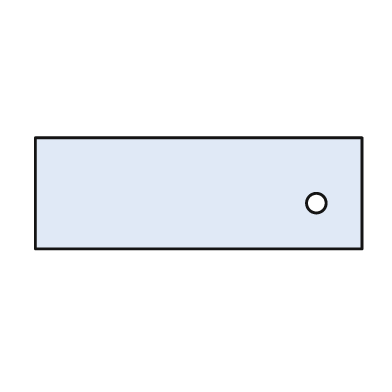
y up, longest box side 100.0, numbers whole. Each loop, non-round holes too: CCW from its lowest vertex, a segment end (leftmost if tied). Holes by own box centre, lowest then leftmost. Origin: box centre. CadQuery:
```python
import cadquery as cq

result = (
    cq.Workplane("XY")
    .moveTo(-50.0, -17.0)
    .lineTo(50.0, -17.0)
    .lineTo(50.0, 17.0)
    .lineTo(-50.0, 17.0)
    .close()
    .moveTo(36.0, -3.0)
    .circle(3.0)
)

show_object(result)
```